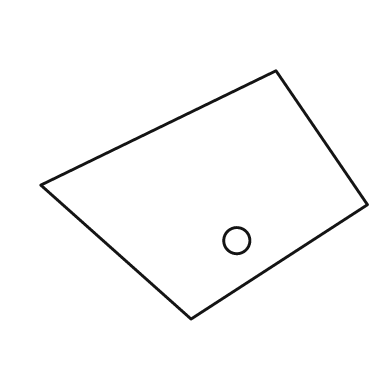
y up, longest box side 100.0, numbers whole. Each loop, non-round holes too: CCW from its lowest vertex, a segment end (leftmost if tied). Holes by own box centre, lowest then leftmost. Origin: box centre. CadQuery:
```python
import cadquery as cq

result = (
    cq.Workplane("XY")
    .moveTo(-4.0, -38.0)
    .lineTo(50.0, -3.0)
    .lineTo(22.0, 38.0)
    .lineTo(-50.0, 3.0)
    .close()
    .moveTo(10.0, -14.0)
    .circle(4.0)
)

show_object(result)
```